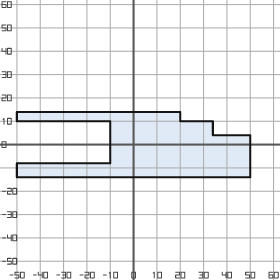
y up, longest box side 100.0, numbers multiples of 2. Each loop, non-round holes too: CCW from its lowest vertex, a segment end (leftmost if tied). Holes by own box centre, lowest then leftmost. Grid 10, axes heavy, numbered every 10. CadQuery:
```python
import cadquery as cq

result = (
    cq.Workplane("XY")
    .moveTo(-50.0, -14.0)
    .lineTo(50.0, -14.0)
    .lineTo(50.0, 4.0)
    .lineTo(34.0, 4.0)
    .lineTo(34.0, 10.0)
    .lineTo(20.0, 10.0)
    .lineTo(20.0, 14.0)
    .lineTo(-50.0, 14.0)
    .lineTo(-50.0, 10.0)
    .lineTo(-10.0, 10.0)
    .lineTo(-10.0, -8.0)
    .lineTo(-50.0, -8.0)
    .close()
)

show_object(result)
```